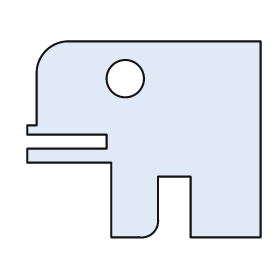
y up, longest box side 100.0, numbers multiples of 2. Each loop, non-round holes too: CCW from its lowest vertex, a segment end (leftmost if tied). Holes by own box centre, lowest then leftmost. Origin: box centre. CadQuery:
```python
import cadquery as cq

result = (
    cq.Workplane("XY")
    .moveTo(-14.0, -42.0)
    .lineTo(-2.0, -42.0)
    .threePointArc((4.0, -40.0), (6.0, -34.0))
    .lineTo(6.0, -16.0)
    .lineTo(20.0, -16.0)
    .lineTo(20.0, -42.0)
    .lineTo(50.0, -42.0)
    .lineTo(50.0, 42.0)
    .lineTo(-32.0, 42.0)
    .threePointArc((-42.0, 38.0), (-46.0, 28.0))
    .lineTo(-46.0, 6.0)
    .lineTo(-50.0, 6.0)
    .lineTo(-50.0, 2.0)
    .lineTo(-16.0, 2.0)
    .lineTo(-16.0, -4.0)
    .lineTo(-50.0, -4.0)
    .lineTo(-50.0, -10.0)
    .lineTo(-14.0, -10.0)
    .close()
    .moveTo(-8.0, 26.0)
    .circle(8.0)
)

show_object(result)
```